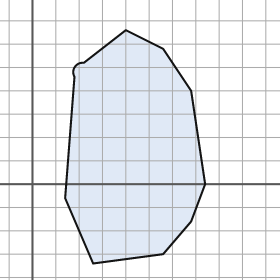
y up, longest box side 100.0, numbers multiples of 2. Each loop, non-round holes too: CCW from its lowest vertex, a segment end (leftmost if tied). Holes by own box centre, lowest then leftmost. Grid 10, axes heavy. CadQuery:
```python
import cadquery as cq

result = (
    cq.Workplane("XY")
    .moveTo(26.0, -34.0)
    .lineTo(56.0, -30.0)
    .lineTo(68.0, -16.0)
    .lineTo(74.0, 0.0)
    .lineTo(68.0, 40.0)
    .lineTo(56.0, 58.0)
    .lineTo(40.0, 66.0)
    .lineTo(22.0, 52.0)
    .threePointArc((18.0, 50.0), (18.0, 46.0))
    .lineTo(14.0, -6.0)
    .close()
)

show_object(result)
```